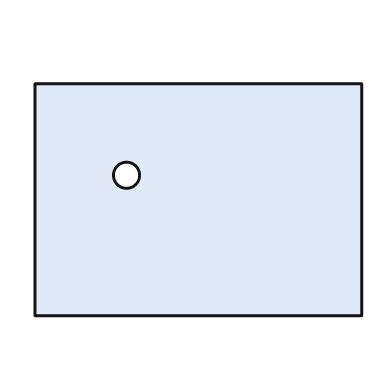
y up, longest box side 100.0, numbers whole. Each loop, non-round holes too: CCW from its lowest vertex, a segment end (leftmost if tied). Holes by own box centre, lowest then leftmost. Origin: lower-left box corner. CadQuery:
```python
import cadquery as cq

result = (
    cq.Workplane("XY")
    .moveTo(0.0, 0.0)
    .lineTo(100.0, 0.0)
    .lineTo(100.0, 71.0)
    .lineTo(0.0, 71.0)
    .close()
    .moveTo(28.0, 43.0)
    .circle(4.0)
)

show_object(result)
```